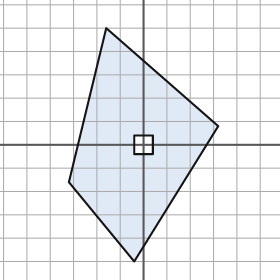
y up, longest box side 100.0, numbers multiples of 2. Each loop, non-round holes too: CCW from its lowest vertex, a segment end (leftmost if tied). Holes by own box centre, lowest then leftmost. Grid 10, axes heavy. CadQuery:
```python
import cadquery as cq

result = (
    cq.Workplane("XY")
    .moveTo(-4.0, -50.0)
    .lineTo(32.0, 8.0)
    .lineTo(-16.0, 50.0)
    .lineTo(-32.0, -16.0)
    .close()
    .moveTo(-4.0, -4.0)
    .lineTo(4.0, -4.0)
    .lineTo(4.0, 4.0)
    .lineTo(-4.0, 4.0)
    .close()
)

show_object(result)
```